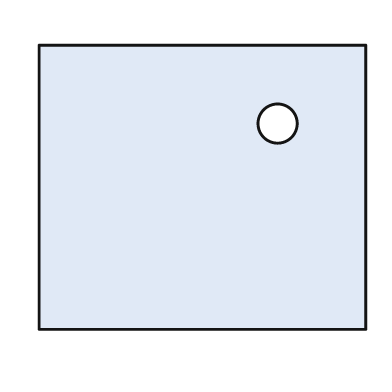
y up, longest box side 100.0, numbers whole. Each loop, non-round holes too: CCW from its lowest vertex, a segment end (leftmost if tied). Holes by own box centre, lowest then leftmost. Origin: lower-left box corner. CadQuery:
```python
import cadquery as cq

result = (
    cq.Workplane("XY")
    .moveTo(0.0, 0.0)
    .lineTo(100.0, 0.0)
    .lineTo(100.0, 87.0)
    .lineTo(0.0, 87.0)
    .close()
    .moveTo(73.0, 63.0)
    .circle(6.0)
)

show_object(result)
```